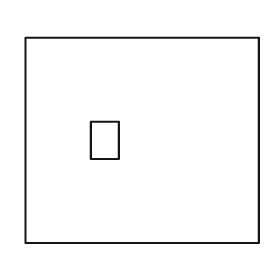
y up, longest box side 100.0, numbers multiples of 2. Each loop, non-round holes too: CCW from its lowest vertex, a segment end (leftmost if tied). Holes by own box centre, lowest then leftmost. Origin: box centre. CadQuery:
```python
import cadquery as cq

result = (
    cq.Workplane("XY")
    .moveTo(-50.0, -44.0)
    .lineTo(50.0, -44.0)
    .lineTo(50.0, 44.0)
    .lineTo(-50.0, 44.0)
    .close()
    .moveTo(-22.0, -8.0)
    .lineTo(-10.0, -8.0)
    .lineTo(-10.0, 8.0)
    .lineTo(-22.0, 8.0)
    .close()
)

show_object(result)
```